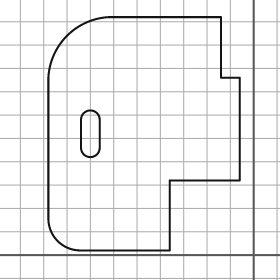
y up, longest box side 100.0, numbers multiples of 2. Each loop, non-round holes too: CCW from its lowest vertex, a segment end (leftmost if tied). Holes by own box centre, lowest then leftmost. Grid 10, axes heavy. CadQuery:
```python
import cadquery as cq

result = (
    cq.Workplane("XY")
    .moveTo(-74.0, 2.0)
    .lineTo(-36.0, 2.0)
    .lineTo(-36.0, 32.0)
    .lineTo(-6.0, 32.0)
    .lineTo(-6.0, 76.0)
    .lineTo(-14.0, 76.0)
    .lineTo(-14.0, 102.0)
    .lineTo(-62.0, 102.0)
    .threePointArc((-80.0, 94.0), (-88.0, 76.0))
    .lineTo(-88.0, 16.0)
    .threePointArc((-84.0, 6.0), (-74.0, 2.0))
    .close()
    .moveTo(-74.0, 46.0)
    .threePointArc((-70.0, 42.0), (-66.0, 46.0))
    .lineTo(-66.0, 58.0)
    .threePointArc((-70.0, 62.0), (-74.0, 58.0))
    .close()
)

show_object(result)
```